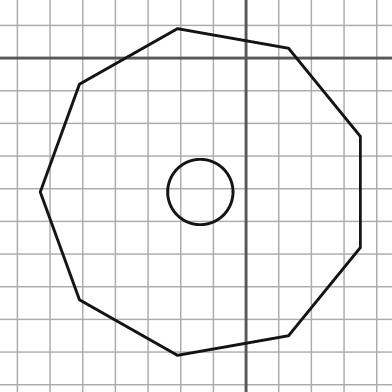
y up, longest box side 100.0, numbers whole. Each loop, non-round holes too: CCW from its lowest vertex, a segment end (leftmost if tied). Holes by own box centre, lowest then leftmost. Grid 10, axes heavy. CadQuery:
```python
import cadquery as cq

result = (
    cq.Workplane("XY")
    .moveTo(-21.0, -91.0)
    .lineTo(13.0, -85.0)
    .lineTo(35.0, -58.0)
    .lineTo(35.0, -24.0)
    .lineTo(13.0, 3.0)
    .lineTo(-21.0, 9.0)
    .lineTo(-51.0, -8.0)
    .lineTo(-63.0, -41.0)
    .lineTo(-51.0, -74.0)
    .close()
    .moveTo(-14.0, -41.0)
    .circle(10.0)
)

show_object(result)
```